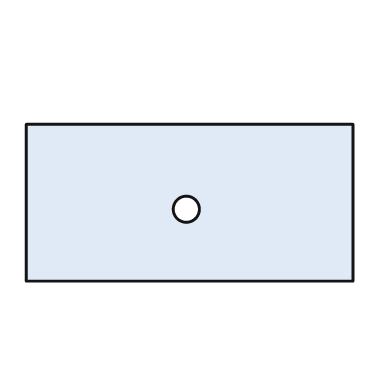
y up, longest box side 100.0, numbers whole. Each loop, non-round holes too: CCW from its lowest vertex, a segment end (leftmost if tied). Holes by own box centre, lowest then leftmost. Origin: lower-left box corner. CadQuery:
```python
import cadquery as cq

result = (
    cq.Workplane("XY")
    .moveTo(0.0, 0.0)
    .lineTo(100.0, 0.0)
    .lineTo(100.0, 48.0)
    .lineTo(0.0, 48.0)
    .close()
    .moveTo(49.0, 22.0)
    .circle(4.0)
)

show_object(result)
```